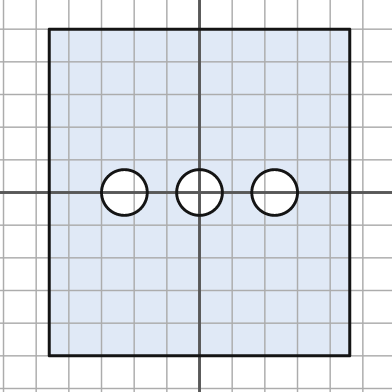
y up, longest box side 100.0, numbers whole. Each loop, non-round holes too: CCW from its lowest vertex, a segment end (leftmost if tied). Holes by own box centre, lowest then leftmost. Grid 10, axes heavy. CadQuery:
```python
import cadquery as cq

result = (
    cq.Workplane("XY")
    .moveTo(-46.0, -50.0)
    .lineTo(46.0, -50.0)
    .lineTo(46.0, 50.0)
    .lineTo(-46.0, 50.0)
    .close()
    .moveTo(-23.0, 0.0)
    .circle(7.0)
    .moveTo(0.0, 0.0)
    .circle(7.0)
    .moveTo(23.0, 0.0)
    .circle(7.0)
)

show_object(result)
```